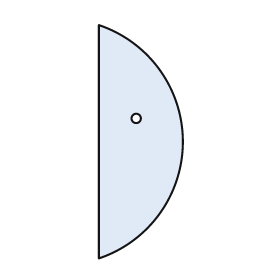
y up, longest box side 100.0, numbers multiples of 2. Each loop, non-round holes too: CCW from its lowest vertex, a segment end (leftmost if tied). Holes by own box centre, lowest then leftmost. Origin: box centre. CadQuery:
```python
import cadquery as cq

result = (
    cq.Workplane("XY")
    .moveTo(-18.0, -50.0)
    .threePointArc((18.0, 0.0), (-18.0, 50.0))
    .close()
    .moveTo(-2.0, 10.0)
    .circle(2.0)
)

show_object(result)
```